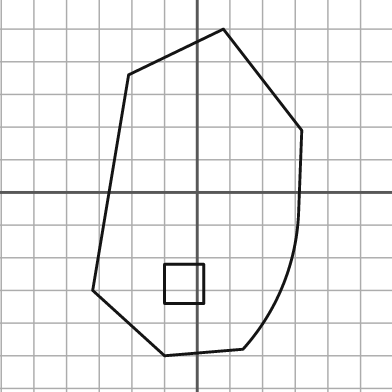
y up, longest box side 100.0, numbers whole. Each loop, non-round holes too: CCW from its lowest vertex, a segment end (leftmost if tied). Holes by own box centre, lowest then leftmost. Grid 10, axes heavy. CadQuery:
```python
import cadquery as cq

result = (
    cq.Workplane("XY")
    .moveTo(-10.0, -50.0)
    .lineTo(14.0, -48.0)
    .threePointArc((26.0, -29.0), (31.0, -7.0))
    .lineTo(32.0, 19.0)
    .lineTo(8.0, 50.0)
    .lineTo(-21.0, 36.0)
    .lineTo(-32.0, -30.0)
    .close()
    .moveTo(-10.0, -34.0)
    .lineTo(2.0, -34.0)
    .lineTo(2.0, -22.0)
    .lineTo(-10.0, -22.0)
    .close()
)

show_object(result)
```